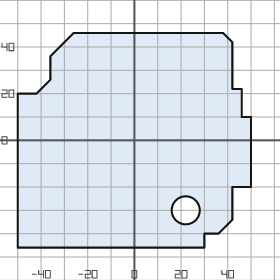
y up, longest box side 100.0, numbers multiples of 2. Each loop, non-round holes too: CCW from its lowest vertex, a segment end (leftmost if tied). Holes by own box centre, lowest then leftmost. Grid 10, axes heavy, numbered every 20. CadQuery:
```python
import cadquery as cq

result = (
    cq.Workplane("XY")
    .moveTo(-50.0, -46.0)
    .lineTo(30.0, -46.0)
    .lineTo(30.0, -40.0)
    .lineTo(36.0, -40.0)
    .lineTo(42.0, -34.0)
    .lineTo(42.0, -20.0)
    .lineTo(50.0, -20.0)
    .lineTo(50.0, 10.0)
    .lineTo(46.0, 10.0)
    .lineTo(46.0, 22.0)
    .lineTo(42.0, 22.0)
    .lineTo(42.0, 42.0)
    .lineTo(38.0, 46.0)
    .lineTo(-26.0, 46.0)
    .lineTo(-36.0, 36.0)
    .lineTo(-36.0, 26.0)
    .lineTo(-42.0, 20.0)
    .lineTo(-50.0, 20.0)
    .close()
    .moveTo(22.0, -30.0)
    .circle(6.0)
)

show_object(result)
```